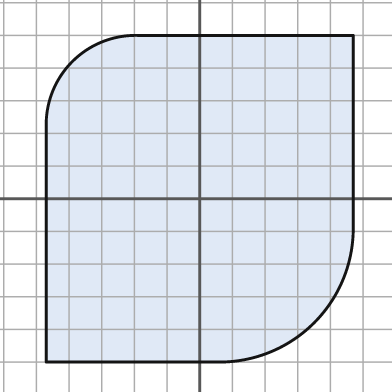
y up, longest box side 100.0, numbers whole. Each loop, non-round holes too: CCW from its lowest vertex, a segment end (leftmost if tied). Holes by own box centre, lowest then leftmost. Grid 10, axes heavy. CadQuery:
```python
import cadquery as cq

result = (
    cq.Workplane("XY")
    .moveTo(-47.0, -50.0)
    .lineTo(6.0, -50.0)
    .threePointArc((35.0, -38.0), (47.0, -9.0))
    .lineTo(47.0, 50.0)
    .lineTo(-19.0, 50.0)
    .threePointArc((-39.0, 42.0), (-47.0, 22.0))
    .close()
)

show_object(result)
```